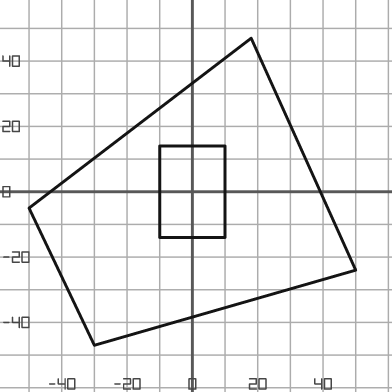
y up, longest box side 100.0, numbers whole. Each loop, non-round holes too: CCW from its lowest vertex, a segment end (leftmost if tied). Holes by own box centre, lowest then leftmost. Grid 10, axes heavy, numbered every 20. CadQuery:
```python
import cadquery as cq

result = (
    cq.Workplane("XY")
    .moveTo(-30.0, -47.0)
    .lineTo(50.0, -24.0)
    .lineTo(18.0, 47.0)
    .lineTo(-50.0, -5.0)
    .close()
    .moveTo(-10.0, -14.0)
    .lineTo(10.0, -14.0)
    .lineTo(10.0, 14.0)
    .lineTo(-10.0, 14.0)
    .close()
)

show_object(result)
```